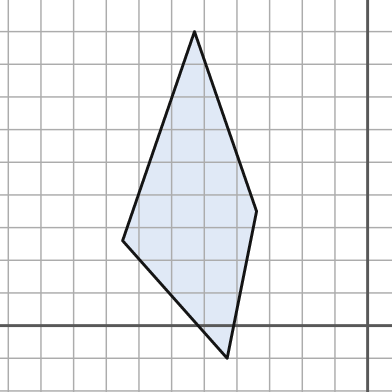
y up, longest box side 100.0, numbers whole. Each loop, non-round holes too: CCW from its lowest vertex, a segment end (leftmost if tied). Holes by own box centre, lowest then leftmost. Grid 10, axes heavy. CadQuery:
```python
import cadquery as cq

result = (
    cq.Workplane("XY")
    .moveTo(-43.0, -10.0)
    .lineTo(-34.0, 35.0)
    .lineTo(-53.0, 90.0)
    .lineTo(-75.0, 26.0)
    .close()
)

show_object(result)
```